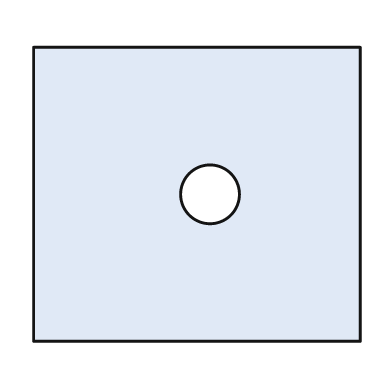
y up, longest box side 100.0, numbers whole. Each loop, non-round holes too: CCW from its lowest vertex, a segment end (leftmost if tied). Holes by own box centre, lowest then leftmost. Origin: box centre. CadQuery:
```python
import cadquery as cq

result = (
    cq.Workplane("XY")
    .moveTo(-50.0, -45.0)
    .lineTo(50.0, -45.0)
    .lineTo(50.0, 45.0)
    .lineTo(-50.0, 45.0)
    .close()
    .moveTo(4.0, 0.0)
    .circle(9.0)
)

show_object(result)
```